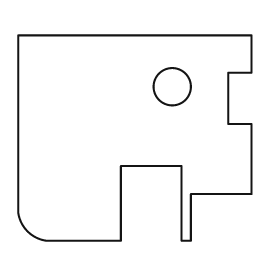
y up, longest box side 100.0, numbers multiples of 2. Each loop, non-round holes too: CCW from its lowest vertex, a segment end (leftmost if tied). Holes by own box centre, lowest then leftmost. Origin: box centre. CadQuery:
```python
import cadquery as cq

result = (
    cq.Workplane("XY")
    .moveTo(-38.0, -44.0)
    .lineTo(-6.0, -44.0)
    .lineTo(-6.0, -12.0)
    .lineTo(20.0, -12.0)
    .lineTo(20.0, -44.0)
    .lineTo(24.0, -44.0)
    .lineTo(24.0, -24.0)
    .lineTo(50.0, -24.0)
    .lineTo(50.0, 6.0)
    .lineTo(40.0, 6.0)
    .lineTo(40.0, 28.0)
    .lineTo(50.0, 28.0)
    .lineTo(50.0, 44.0)
    .lineTo(-50.0, 44.0)
    .lineTo(-50.0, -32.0)
    .threePointArc((-46.0, -40.0), (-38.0, -44.0))
    .close()
    .moveTo(16.0, 22.0)
    .circle(8.0)
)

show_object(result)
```